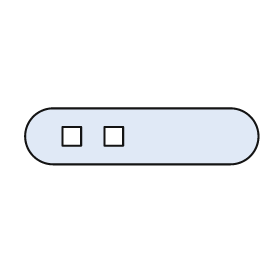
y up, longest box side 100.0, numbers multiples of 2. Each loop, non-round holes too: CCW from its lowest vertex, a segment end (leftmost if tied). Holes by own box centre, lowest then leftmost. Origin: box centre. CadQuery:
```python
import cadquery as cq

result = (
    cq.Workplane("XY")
    .moveTo(-38.0, -12.0)
    .lineTo(38.0, -12.0)
    .threePointArc((50.0, 0.0), (38.0, 12.0))
    .lineTo(-38.0, 12.0)
    .threePointArc((-50.0, 0.0), (-38.0, -12.0))
    .close()
    .moveTo(-34.0, -4.0)
    .lineTo(-26.0, -4.0)
    .lineTo(-26.0, 4.0)
    .lineTo(-34.0, 4.0)
    .close()
    .moveTo(-16.0, -4.0)
    .lineTo(-8.0, -4.0)
    .lineTo(-8.0, 4.0)
    .lineTo(-16.0, 4.0)
    .close()
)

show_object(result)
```